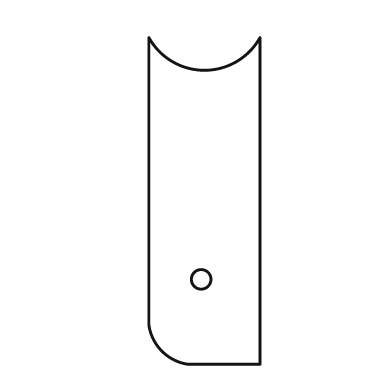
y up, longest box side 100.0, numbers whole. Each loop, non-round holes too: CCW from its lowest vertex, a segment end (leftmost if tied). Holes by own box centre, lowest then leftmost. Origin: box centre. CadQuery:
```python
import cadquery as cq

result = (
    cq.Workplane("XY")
    .moveTo(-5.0, -50.0)
    .lineTo(17.0, -50.0)
    .lineTo(17.0, 50.0)
    .threePointArc((0.0, 40.0), (-17.0, 50.0))
    .lineTo(-17.0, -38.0)
    .threePointArc((-13.0, -46.0), (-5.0, -50.0))
    .close()
    .moveTo(-1.0, -24.0)
    .circle(3.0)
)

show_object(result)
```